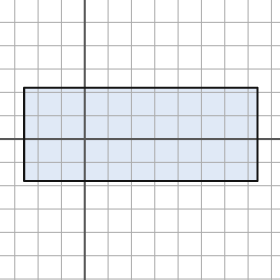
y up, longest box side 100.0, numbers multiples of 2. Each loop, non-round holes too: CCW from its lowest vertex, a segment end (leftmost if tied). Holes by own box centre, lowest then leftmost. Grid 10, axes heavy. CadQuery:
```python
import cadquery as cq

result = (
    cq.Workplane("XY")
    .moveTo(-26.0, -18.0)
    .lineTo(74.0, -18.0)
    .lineTo(74.0, 22.0)
    .lineTo(-26.0, 22.0)
    .close()
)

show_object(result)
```